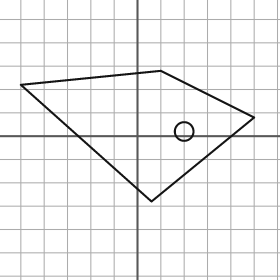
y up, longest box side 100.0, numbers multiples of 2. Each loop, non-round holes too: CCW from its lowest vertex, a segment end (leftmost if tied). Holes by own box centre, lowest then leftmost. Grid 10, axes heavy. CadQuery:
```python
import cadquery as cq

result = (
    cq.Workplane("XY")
    .moveTo(6.0, -28.0)
    .lineTo(50.0, 8.0)
    .lineTo(10.0, 28.0)
    .lineTo(-50.0, 22.0)
    .close()
    .moveTo(20.0, 2.0)
    .circle(4.0)
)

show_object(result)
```